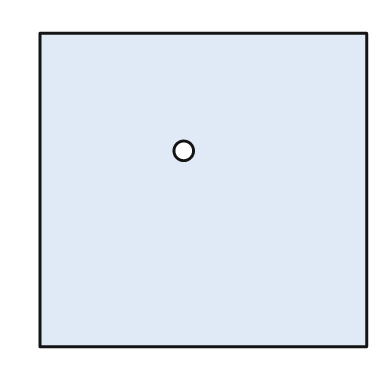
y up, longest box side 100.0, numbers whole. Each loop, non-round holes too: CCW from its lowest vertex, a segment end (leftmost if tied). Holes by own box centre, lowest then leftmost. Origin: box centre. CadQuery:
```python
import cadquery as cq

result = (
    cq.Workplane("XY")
    .moveTo(-50.0, -48.0)
    .lineTo(50.0, -48.0)
    .lineTo(50.0, 48.0)
    .lineTo(-50.0, 48.0)
    .close()
    .moveTo(-6.0, 12.0)
    .circle(3.0)
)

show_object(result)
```